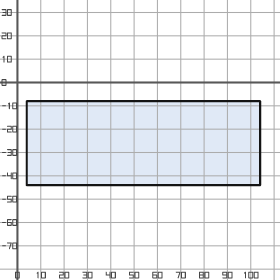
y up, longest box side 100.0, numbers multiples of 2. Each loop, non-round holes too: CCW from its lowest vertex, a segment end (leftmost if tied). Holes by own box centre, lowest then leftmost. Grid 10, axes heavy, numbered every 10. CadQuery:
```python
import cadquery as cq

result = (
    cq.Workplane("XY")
    .moveTo(4.0, -44.0)
    .lineTo(104.0, -44.0)
    .lineTo(104.0, -8.0)
    .lineTo(4.0, -8.0)
    .close()
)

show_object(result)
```